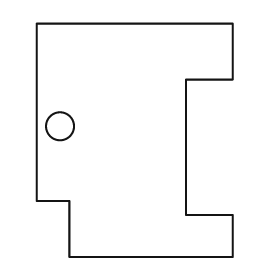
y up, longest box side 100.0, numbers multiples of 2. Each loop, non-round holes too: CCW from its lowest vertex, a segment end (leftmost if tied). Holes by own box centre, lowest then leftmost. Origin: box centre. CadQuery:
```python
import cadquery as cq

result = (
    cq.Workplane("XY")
    .moveTo(-28.0, -50.0)
    .lineTo(42.0, -50.0)
    .lineTo(42.0, -32.0)
    .lineTo(22.0, -32.0)
    .lineTo(22.0, 26.0)
    .lineTo(42.0, 26.0)
    .lineTo(42.0, 50.0)
    .lineTo(-42.0, 50.0)
    .lineTo(-42.0, -26.0)
    .lineTo(-28.0, -26.0)
    .close()
    .moveTo(-32.0, 6.0)
    .circle(6.0)
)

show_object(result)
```